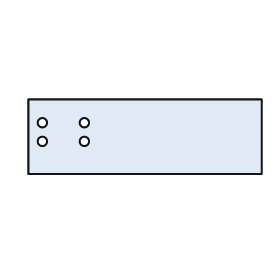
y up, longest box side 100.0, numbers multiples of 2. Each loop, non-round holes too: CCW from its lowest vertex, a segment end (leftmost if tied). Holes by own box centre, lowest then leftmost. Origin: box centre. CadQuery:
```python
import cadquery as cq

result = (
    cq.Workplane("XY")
    .moveTo(-50.0, -16.0)
    .lineTo(50.0, -16.0)
    .lineTo(50.0, 16.0)
    .lineTo(-50.0, 16.0)
    .close()
    .moveTo(-44.0, -2.0)
    .circle(2.0)
    .moveTo(-26.0, -2.0)
    .circle(2.0)
    .moveTo(-44.0, 6.0)
    .circle(2.0)
    .moveTo(-26.0, 6.0)
    .circle(2.0)
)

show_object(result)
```